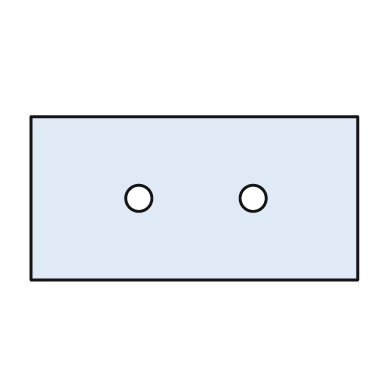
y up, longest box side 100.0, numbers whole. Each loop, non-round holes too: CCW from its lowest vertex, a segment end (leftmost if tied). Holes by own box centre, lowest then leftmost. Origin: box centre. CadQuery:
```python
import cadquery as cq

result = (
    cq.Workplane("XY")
    .moveTo(-50.0, -25.0)
    .lineTo(50.0, -25.0)
    .lineTo(50.0, 25.0)
    .lineTo(-50.0, 25.0)
    .close()
    .moveTo(-17.0, 0.0)
    .circle(4.0)
    .moveTo(18.0, 0.0)
    .circle(4.0)
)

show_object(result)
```